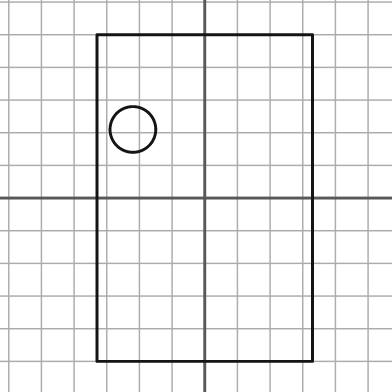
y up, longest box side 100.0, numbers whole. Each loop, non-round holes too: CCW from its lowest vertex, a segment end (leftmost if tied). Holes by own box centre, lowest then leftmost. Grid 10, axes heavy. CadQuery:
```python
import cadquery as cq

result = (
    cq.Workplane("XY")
    .moveTo(-33.0, -50.0)
    .lineTo(33.0, -50.0)
    .lineTo(33.0, 50.0)
    .lineTo(-33.0, 50.0)
    .close()
    .moveTo(-22.0, 21.0)
    .circle(7.0)
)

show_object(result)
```